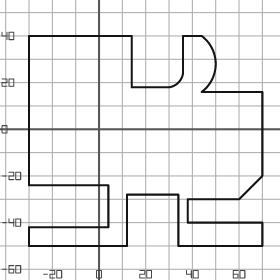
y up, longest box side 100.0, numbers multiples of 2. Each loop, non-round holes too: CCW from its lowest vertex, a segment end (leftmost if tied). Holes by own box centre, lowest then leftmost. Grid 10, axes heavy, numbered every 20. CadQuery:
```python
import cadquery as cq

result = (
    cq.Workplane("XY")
    .moveTo(-30.0, -50.0)
    .lineTo(12.0, -50.0)
    .lineTo(12.0, -28.0)
    .lineTo(34.0, -28.0)
    .lineTo(34.0, -50.0)
    .lineTo(70.0, -50.0)
    .lineTo(70.0, -40.0)
    .lineTo(38.0, -40.0)
    .lineTo(38.0, -30.0)
    .lineTo(60.0, -30.0)
    .lineTo(70.0, -20.0)
    .lineTo(70.0, 16.0)
    .lineTo(44.0, 16.0)
    .threePointArc((50.0, 28.0), (44.0, 40.0))
    .lineTo(36.0, 40.0)
    .lineTo(36.0, 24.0)
    .threePointArc((34.0, 20.0), (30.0, 18.0))
    .lineTo(14.0, 18.0)
    .lineTo(14.0, 40.0)
    .lineTo(-30.0, 40.0)
    .lineTo(-30.0, -24.0)
    .lineTo(4.0, -24.0)
    .lineTo(4.0, -42.0)
    .lineTo(-30.0, -42.0)
    .close()
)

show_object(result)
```